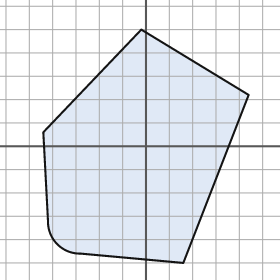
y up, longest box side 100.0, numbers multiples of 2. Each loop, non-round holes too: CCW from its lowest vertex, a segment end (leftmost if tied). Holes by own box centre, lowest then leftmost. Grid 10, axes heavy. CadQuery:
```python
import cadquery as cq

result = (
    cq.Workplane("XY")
    .moveTo(16.0, -50.0)
    .lineTo(44.0, 22.0)
    .lineTo(-2.0, 50.0)
    .lineTo(-44.0, 6.0)
    .lineTo(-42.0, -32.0)
    .threePointArc((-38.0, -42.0), (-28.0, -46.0))
    .close()
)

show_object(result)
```